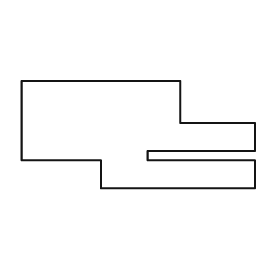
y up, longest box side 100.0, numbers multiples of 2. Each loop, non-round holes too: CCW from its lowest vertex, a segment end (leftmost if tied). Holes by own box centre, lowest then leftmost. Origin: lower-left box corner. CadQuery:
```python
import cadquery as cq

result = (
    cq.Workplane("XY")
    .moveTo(34.0, 0.0)
    .lineTo(100.0, 0.0)
    .lineTo(100.0, 12.0)
    .lineTo(54.0, 12.0)
    .lineTo(54.0, 16.0)
    .lineTo(100.0, 16.0)
    .lineTo(100.0, 28.0)
    .lineTo(68.0, 28.0)
    .lineTo(68.0, 46.0)
    .lineTo(0.0, 46.0)
    .lineTo(0.0, 12.0)
    .lineTo(34.0, 12.0)
    .close()
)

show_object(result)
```